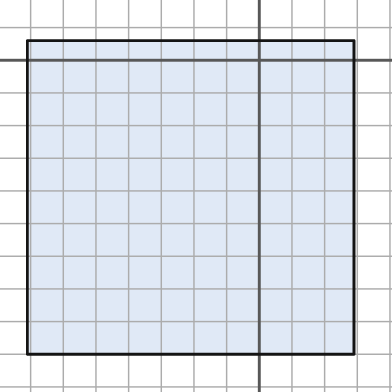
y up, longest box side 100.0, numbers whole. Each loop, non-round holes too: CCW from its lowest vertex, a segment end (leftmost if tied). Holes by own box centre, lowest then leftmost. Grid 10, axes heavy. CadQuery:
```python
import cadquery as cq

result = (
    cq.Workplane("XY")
    .moveTo(-71.0, -90.0)
    .lineTo(29.0, -90.0)
    .lineTo(29.0, 6.0)
    .lineTo(-71.0, 6.0)
    .close()
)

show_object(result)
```